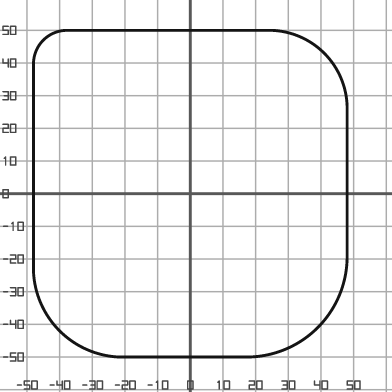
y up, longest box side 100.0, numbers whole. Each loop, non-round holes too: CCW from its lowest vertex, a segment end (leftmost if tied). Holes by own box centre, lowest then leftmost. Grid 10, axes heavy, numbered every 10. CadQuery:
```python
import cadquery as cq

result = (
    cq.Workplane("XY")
    .moveTo(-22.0, -50.0)
    .lineTo(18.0, -50.0)
    .threePointArc((39.0, -41.0), (48.0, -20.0))
    .lineTo(48.0, 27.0)
    .threePointArc((41.0, 43.0), (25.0, 50.0))
    .lineTo(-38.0, 50.0)
    .threePointArc((-45.0, 47.0), (-48.0, 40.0))
    .lineTo(-48.0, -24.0)
    .threePointArc((-40.0, -42.0), (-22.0, -50.0))
    .close()
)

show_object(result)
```